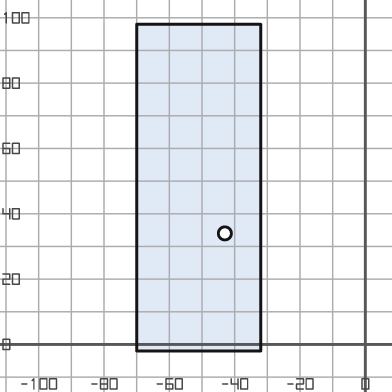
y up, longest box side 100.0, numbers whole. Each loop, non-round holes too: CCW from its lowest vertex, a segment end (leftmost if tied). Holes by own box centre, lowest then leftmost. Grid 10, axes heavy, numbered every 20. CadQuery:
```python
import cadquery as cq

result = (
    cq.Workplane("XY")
    .moveTo(-70.0, -2.0)
    .lineTo(-32.0, -2.0)
    .lineTo(-32.0, 98.0)
    .lineTo(-70.0, 98.0)
    .close()
    .moveTo(-43.0, 34.0)
    .circle(2.0)
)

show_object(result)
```